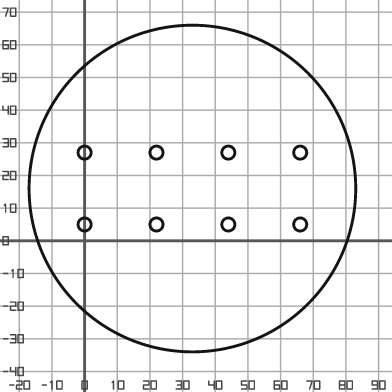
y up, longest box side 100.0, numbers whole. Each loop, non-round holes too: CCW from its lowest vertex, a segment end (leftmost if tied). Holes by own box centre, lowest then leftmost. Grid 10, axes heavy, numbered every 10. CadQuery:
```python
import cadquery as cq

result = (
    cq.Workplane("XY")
    .moveTo(33.0, 16.0)
    .circle(50.0)
    .moveTo(0.0, 5.0)
    .circle(2.0)
    .moveTo(22.0, 5.0)
    .circle(2.0)
    .moveTo(44.0, 5.0)
    .circle(2.0)
    .moveTo(66.0, 5.0)
    .circle(2.0)
    .moveTo(0.0, 27.0)
    .circle(2.0)
    .moveTo(22.0, 27.0)
    .circle(2.0)
    .moveTo(44.0, 27.0)
    .circle(2.0)
    .moveTo(66.0, 27.0)
    .circle(2.0)
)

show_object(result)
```